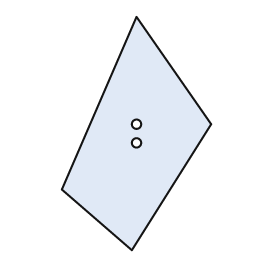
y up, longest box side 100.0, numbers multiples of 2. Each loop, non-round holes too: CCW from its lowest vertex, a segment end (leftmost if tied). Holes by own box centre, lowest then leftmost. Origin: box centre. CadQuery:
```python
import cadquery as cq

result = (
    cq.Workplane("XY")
    .moveTo(-2.0, -50.0)
    .lineTo(32.0, 4.0)
    .lineTo(0.0, 50.0)
    .lineTo(-32.0, -24.0)
    .close()
    .moveTo(0.0, -4.0)
    .circle(2.0)
    .moveTo(0.0, 4.0)
    .circle(2.0)
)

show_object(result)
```